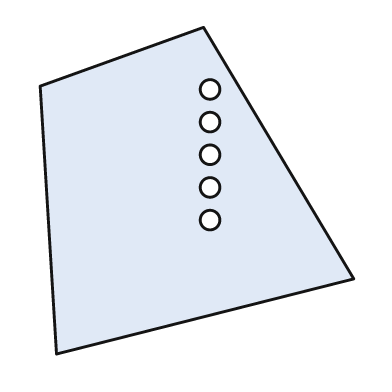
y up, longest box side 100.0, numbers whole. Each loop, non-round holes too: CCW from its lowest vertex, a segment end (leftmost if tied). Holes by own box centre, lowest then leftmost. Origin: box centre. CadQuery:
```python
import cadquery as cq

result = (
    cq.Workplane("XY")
    .moveTo(-43.0, -50.0)
    .lineTo(48.0, -27.0)
    .lineTo(2.0, 50.0)
    .lineTo(-48.0, 32.0)
    .close()
    .moveTo(4.0, -9.0)
    .circle(3.0)
    .moveTo(4.0, 1.0)
    .circle(3.0)
    .moveTo(4.0, 11.0)
    .circle(3.0)
    .moveTo(4.0, 21.0)
    .circle(3.0)
    .moveTo(4.0, 31.0)
    .circle(3.0)
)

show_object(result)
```